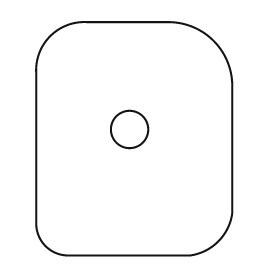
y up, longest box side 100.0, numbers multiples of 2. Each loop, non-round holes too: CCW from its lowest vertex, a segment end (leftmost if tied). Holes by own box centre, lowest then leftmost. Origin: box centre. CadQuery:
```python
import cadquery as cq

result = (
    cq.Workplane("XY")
    .moveTo(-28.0, -50.0)
    .lineTo(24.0, -50.0)
    .threePointArc((36.0, -44.0), (42.0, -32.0))
    .lineTo(42.0, 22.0)
    .threePointArc((34.0, 42.0), (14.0, 50.0))
    .lineTo(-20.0, 50.0)
    .threePointArc((-36.0, 44.0), (-42.0, 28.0))
    .lineTo(-42.0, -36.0)
    .threePointArc((-38.0, -46.0), (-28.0, -50.0))
    .close()
    .moveTo(-2.0, 4.0)
    .circle(8.0)
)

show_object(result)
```